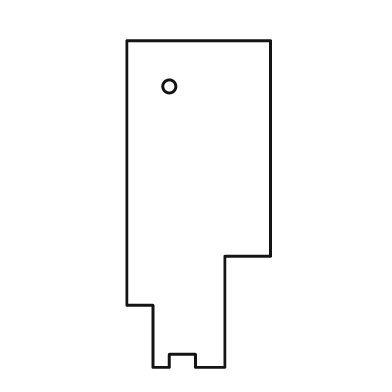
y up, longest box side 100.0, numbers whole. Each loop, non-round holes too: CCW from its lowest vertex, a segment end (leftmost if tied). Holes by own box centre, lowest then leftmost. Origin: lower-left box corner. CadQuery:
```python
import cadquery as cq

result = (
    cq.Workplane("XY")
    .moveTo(8.0, 0.0)
    .lineTo(13.0, 0.0)
    .lineTo(13.0, 4.0)
    .lineTo(21.0, 4.0)
    .lineTo(21.0, 0.0)
    .lineTo(30.0, 0.0)
    .lineTo(30.0, 34.0)
    .lineTo(44.0, 34.0)
    .lineTo(44.0, 100.0)
    .lineTo(0.0, 100.0)
    .lineTo(0.0, 19.0)
    .lineTo(8.0, 19.0)
    .close()
    .moveTo(13.0, 86.0)
    .circle(2.0)
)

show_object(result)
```